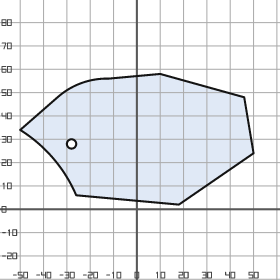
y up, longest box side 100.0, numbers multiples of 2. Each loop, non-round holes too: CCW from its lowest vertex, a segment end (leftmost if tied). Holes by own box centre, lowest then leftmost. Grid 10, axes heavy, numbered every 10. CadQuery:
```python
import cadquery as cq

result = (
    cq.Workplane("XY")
    .moveTo(18.0, 2.0)
    .lineTo(50.0, 24.0)
    .lineTo(46.0, 48.0)
    .lineTo(10.0, 58.0)
    .lineTo(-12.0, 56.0)
    .threePointArc((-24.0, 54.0), (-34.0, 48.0))
    .lineTo(-50.0, 34.0)
    .threePointArc((-36.0, 22.0), (-26.0, 6.0))
    .close()
    .moveTo(-28.0, 28.0)
    .circle(2.0)
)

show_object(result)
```